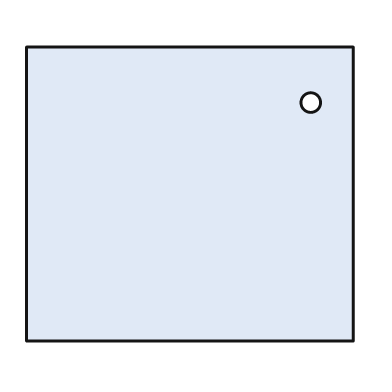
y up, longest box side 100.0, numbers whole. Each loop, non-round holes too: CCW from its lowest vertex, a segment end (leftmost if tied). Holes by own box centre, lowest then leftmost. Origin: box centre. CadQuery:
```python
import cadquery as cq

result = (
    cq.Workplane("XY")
    .moveTo(-50.0, -45.0)
    .lineTo(50.0, -45.0)
    .lineTo(50.0, 45.0)
    .lineTo(-50.0, 45.0)
    .close()
    .moveTo(37.0, 28.0)
    .circle(3.0)
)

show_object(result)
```